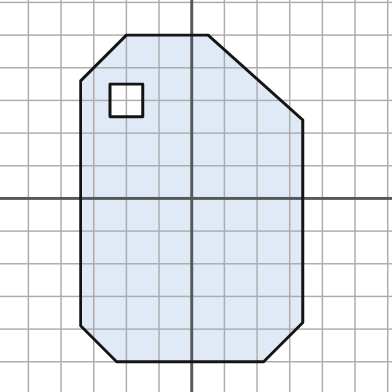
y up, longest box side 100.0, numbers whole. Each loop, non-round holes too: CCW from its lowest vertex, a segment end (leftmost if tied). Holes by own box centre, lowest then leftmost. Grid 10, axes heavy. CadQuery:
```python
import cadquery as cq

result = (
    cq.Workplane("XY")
    .moveTo(-23.0, -50.0)
    .lineTo(22.0, -50.0)
    .lineTo(34.0, -38.0)
    .lineTo(34.0, 24.0)
    .lineTo(5.0, 50.0)
    .lineTo(-20.0, 50.0)
    .lineTo(-34.0, 36.0)
    .lineTo(-34.0, -39.0)
    .close()
    .moveTo(-25.0, 25.0)
    .lineTo(-15.0, 25.0)
    .lineTo(-15.0, 35.0)
    .lineTo(-25.0, 35.0)
    .close()
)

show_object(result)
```